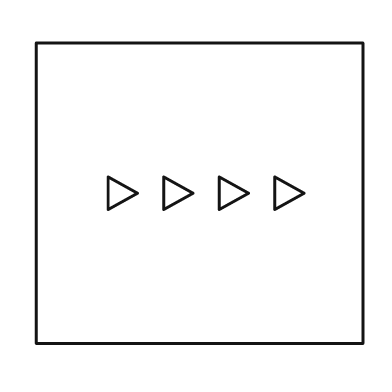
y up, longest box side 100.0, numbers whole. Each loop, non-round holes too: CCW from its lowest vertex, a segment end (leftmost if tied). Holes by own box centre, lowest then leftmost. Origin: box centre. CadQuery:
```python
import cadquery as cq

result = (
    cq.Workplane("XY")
    .moveTo(-50.0, -46.0)
    .lineTo(50.0, -46.0)
    .lineTo(50.0, 46.0)
    .lineTo(-50.0, 46.0)
    .close()
    .moveTo(-28.0, -5.0)
    .lineTo(-19.0, 0.0)
    .lineTo(-28.0, 5.0)
    .close()
    .moveTo(-11.0, -5.0)
    .lineTo(-2.0, 0.0)
    .lineTo(-11.0, 5.0)
    .close()
    .moveTo(6.0, -5.0)
    .lineTo(15.0, 0.0)
    .lineTo(6.0, 5.0)
    .close()
    .moveTo(23.0, -5.0)
    .lineTo(32.0, 0.0)
    .lineTo(23.0, 5.0)
    .close()
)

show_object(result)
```